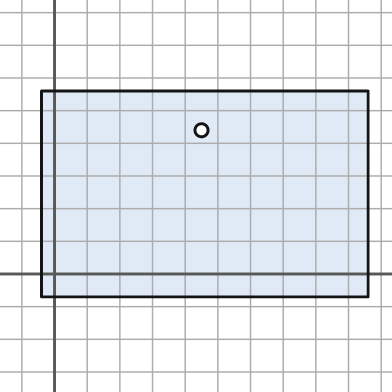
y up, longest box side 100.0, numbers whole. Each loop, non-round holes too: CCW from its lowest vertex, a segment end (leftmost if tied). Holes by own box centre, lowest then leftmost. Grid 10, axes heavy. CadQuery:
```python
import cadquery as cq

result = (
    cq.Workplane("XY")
    .moveTo(-4.0, -7.0)
    .lineTo(96.0, -7.0)
    .lineTo(96.0, 56.0)
    .lineTo(-4.0, 56.0)
    .close()
    .moveTo(45.0, 44.0)
    .circle(2.0)
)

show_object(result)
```